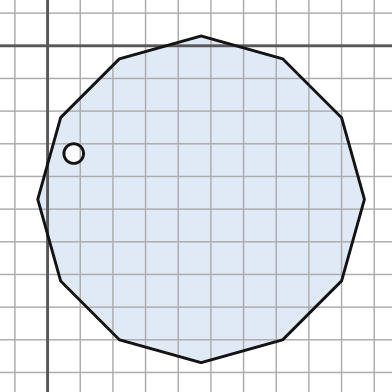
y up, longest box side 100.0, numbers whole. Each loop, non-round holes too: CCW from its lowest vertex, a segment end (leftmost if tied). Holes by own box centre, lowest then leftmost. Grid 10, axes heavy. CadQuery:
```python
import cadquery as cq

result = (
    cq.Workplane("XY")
    .moveTo(47.0, -97.0)
    .lineTo(72.0, -90.0)
    .lineTo(90.0, -72.0)
    .lineTo(97.0, -47.0)
    .lineTo(90.0, -22.0)
    .lineTo(72.0, -4.0)
    .lineTo(47.0, 3.0)
    .lineTo(22.0, -4.0)
    .lineTo(4.0, -22.0)
    .lineTo(-3.0, -47.0)
    .lineTo(4.0, -72.0)
    .lineTo(22.0, -90.0)
    .close()
    .moveTo(8.0, -33.0)
    .circle(3.0)
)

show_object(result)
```